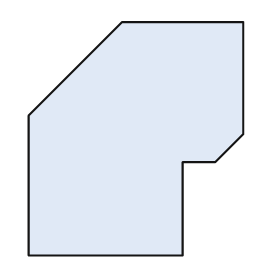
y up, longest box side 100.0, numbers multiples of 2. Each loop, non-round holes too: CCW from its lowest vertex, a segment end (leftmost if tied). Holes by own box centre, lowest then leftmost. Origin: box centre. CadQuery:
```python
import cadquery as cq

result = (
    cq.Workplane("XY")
    .moveTo(-46.0, -50.0)
    .lineTo(20.0, -50.0)
    .lineTo(20.0, -10.0)
    .lineTo(34.0, -10.0)
    .lineTo(46.0, 2.0)
    .lineTo(46.0, 50.0)
    .lineTo(-6.0, 50.0)
    .lineTo(-46.0, 10.0)
    .close()
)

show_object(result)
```